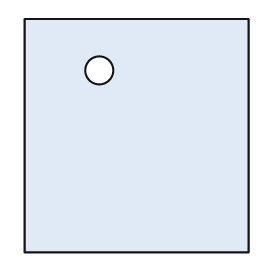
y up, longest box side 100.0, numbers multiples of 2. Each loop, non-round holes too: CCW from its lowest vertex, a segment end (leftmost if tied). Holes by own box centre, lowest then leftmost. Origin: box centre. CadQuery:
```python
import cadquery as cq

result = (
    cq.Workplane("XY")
    .moveTo(-48.0, -50.0)
    .lineTo(48.0, -50.0)
    .lineTo(48.0, 50.0)
    .lineTo(-48.0, 50.0)
    .close()
    .moveTo(-16.0, 28.0)
    .circle(6.0)
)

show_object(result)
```